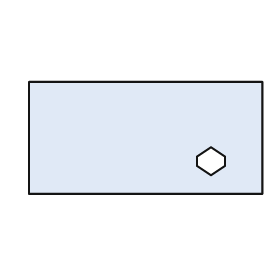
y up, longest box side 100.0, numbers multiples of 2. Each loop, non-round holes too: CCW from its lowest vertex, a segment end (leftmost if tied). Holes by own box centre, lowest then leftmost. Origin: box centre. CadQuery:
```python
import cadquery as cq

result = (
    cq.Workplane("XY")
    .moveTo(-50.0, -24.0)
    .lineTo(50.0, -24.0)
    .lineTo(50.0, 24.0)
    .lineTo(-50.0, 24.0)
    .close()
    .moveTo(28.0, -16.0)
    .lineTo(34.0, -12.0)
    .lineTo(34.0, -8.0)
    .lineTo(28.0, -4.0)
    .lineTo(22.0, -8.0)
    .lineTo(22.0, -12.0)
    .close()
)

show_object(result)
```